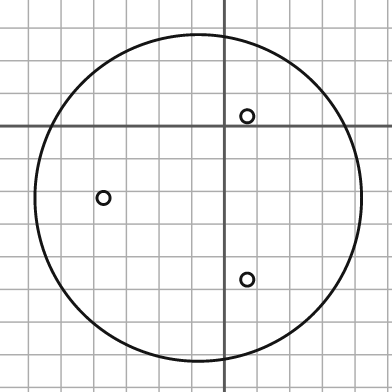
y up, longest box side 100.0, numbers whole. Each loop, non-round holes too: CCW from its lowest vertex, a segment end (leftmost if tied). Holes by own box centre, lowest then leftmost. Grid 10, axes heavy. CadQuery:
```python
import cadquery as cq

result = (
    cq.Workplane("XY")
    .moveTo(-8.0, -22.0)
    .circle(50.0)
    .moveTo(7.0, -47.0)
    .circle(2.0)
    .moveTo(-37.0, -22.0)
    .circle(2.0)
    .moveTo(7.0, 3.0)
    .circle(2.0)
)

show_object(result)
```